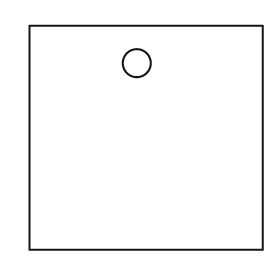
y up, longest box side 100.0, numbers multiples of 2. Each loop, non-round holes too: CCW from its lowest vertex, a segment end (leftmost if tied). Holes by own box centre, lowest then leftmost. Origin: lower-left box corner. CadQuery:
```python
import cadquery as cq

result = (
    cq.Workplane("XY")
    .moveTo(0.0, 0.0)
    .lineTo(100.0, 0.0)
    .lineTo(100.0, 96.0)
    .lineTo(0.0, 96.0)
    .close()
    .moveTo(46.0, 80.0)
    .circle(6.0)
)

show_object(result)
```